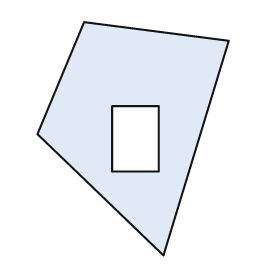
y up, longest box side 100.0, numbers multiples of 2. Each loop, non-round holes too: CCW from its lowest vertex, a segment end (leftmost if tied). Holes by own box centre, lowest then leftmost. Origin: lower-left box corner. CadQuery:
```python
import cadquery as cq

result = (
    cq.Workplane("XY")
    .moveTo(54.0, 0.0)
    .lineTo(82.0, 92.0)
    .lineTo(20.0, 100.0)
    .lineTo(0.0, 52.0)
    .close()
    .moveTo(32.0, 36.0)
    .lineTo(52.0, 36.0)
    .lineTo(52.0, 64.0)
    .lineTo(32.0, 64.0)
    .close()
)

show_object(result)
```